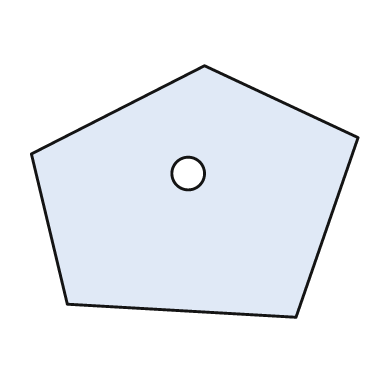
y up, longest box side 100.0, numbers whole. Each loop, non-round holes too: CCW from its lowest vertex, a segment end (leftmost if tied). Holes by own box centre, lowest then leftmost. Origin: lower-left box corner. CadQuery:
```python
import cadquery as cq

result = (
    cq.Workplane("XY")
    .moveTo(81.0, 0.0)
    .lineTo(100.0, 55.0)
    .lineTo(53.0, 77.0)
    .lineTo(0.0, 50.0)
    .lineTo(11.0, 4.0)
    .close()
    .moveTo(48.0, 44.0)
    .circle(5.0)
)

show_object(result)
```